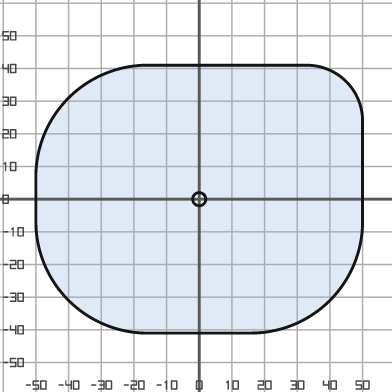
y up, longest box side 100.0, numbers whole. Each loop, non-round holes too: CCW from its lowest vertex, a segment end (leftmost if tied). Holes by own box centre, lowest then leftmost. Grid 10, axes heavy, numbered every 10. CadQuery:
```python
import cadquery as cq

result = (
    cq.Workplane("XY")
    .moveTo(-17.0, -41.0)
    .lineTo(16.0, -41.0)
    .threePointArc((40.0, -31.0), (50.0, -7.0))
    .lineTo(50.0, 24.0)
    .threePointArc((45.0, 36.0), (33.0, 41.0))
    .lineTo(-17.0, 41.0)
    .threePointArc((-40.0, 31.0), (-50.0, 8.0))
    .lineTo(-50.0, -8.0)
    .threePointArc((-40.0, -31.0), (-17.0, -41.0))
    .close()
    .moveTo(0.0, 0.0)
    .circle(2.0)
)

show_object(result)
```